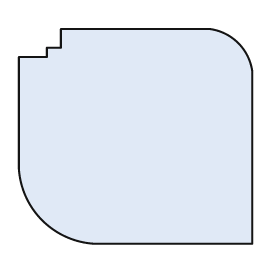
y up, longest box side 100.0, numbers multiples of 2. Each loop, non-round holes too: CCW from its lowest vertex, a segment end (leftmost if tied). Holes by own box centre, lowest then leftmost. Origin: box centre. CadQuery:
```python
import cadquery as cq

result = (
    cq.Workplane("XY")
    .moveTo(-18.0, -46.0)
    .lineTo(50.0, -46.0)
    .lineTo(50.0, 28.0)
    .threePointArc((44.0, 40.0), (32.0, 46.0))
    .lineTo(-32.0, 46.0)
    .lineTo(-32.0, 38.0)
    .lineTo(-38.0, 38.0)
    .lineTo(-38.0, 34.0)
    .lineTo(-50.0, 34.0)
    .lineTo(-50.0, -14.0)
    .threePointArc((-40.0, -36.0), (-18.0, -46.0))
    .close()
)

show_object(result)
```